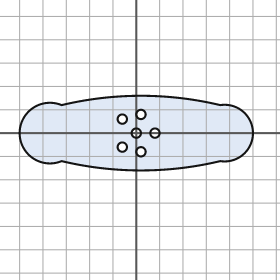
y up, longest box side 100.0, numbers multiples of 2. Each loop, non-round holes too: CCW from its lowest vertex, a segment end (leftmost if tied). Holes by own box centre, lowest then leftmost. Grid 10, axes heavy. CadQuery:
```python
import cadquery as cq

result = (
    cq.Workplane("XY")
    .moveTo(-32.0, -12.0)
    .threePointArc((2.0, -16.0), (36.0, -12.0))
    .threePointArc((50.0, 0.0), (36.0, 12.0))
    .threePointArc((2.0, 16.0), (-32.0, 12.0))
    .threePointArc((-50.0, 0.0), (-32.0, -12.0))
    .close()
    .moveTo(2.0, -8.0)
    .circle(2.0)
    .moveTo(-6.0, -6.0)
    .circle(2.0)
    .moveTo(0.0, 0.0)
    .circle(2.0)
    .moveTo(8.0, 0.0)
    .circle(2.0)
    .moveTo(-6.0, 6.0)
    .circle(2.0)
    .moveTo(2.0, 8.0)
    .circle(2.0)
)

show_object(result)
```